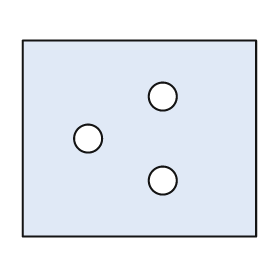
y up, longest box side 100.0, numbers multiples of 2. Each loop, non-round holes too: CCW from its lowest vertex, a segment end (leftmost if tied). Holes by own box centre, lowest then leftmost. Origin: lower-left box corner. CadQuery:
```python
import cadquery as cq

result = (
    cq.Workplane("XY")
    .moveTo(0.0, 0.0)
    .lineTo(100.0, 0.0)
    .lineTo(100.0, 84.0)
    .lineTo(0.0, 84.0)
    .close()
    .moveTo(60.0, 24.0)
    .circle(6.0)
    .moveTo(28.0, 42.0)
    .circle(6.0)
    .moveTo(60.0, 60.0)
    .circle(6.0)
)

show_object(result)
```